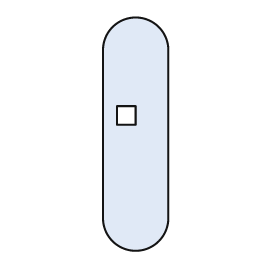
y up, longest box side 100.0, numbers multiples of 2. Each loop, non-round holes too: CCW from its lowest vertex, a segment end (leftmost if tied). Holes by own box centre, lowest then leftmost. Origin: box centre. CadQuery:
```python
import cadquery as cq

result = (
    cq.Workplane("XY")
    .moveTo(-14.0, -36.0)
    .threePointArc((0.0, -50.0), (14.0, -36.0))
    .lineTo(14.0, 36.0)
    .threePointArc((0.0, 50.0), (-14.0, 36.0))
    .close()
    .moveTo(-8.0, 4.0)
    .lineTo(0.0, 4.0)
    .lineTo(0.0, 12.0)
    .lineTo(-8.0, 12.0)
    .close()
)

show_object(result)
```